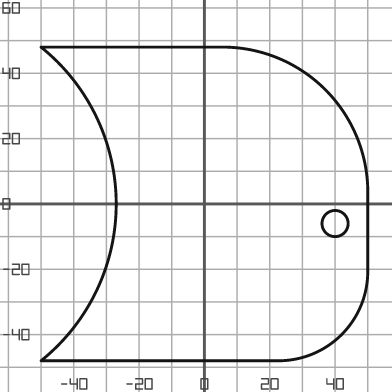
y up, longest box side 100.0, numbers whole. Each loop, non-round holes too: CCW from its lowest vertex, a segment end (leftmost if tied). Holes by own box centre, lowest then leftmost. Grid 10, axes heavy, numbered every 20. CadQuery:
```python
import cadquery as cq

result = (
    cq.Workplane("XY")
    .moveTo(-50.0, -48.0)
    .lineTo(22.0, -48.0)
    .threePointArc((42.0, -40.0), (50.0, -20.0))
    .lineTo(50.0, 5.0)
    .threePointArc((37.0, 35.0), (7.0, 48.0))
    .lineTo(-50.0, 48.0)
    .threePointArc((-27.0, 0.0), (-50.0, -48.0))
    .close()
    .moveTo(40.0, -6.0)
    .circle(4.0)
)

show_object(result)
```